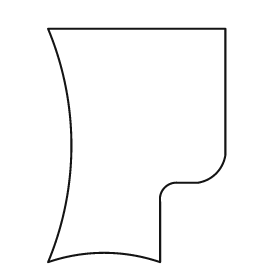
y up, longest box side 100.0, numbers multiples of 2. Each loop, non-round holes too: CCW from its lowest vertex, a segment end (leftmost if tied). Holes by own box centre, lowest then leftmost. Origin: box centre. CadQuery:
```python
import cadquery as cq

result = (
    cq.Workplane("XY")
    .moveTo(-38.0, -50.0)
    .threePointArc((-14.0, -46.0), (10.0, -50.0))
    .lineTo(10.0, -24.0)
    .threePointArc((12.0, -18.0), (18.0, -16.0))
    .lineTo(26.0, -16.0)
    .threePointArc((34.0, -12.0), (38.0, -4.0))
    .lineTo(38.0, 50.0)
    .lineTo(-38.0, 50.0)
    .threePointArc((-28.0, 0.0), (-38.0, -50.0))
    .close()
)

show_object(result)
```